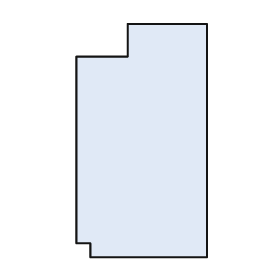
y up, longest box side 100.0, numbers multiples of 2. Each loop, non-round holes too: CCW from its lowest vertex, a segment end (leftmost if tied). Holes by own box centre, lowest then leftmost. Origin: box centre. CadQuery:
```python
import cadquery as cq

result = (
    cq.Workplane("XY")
    .moveTo(-22.0, -50.0)
    .lineTo(28.0, -50.0)
    .lineTo(28.0, 50.0)
    .lineTo(-6.0, 50.0)
    .lineTo(-6.0, 36.0)
    .lineTo(-28.0, 36.0)
    .lineTo(-28.0, -44.0)
    .lineTo(-22.0, -44.0)
    .close()
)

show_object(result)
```